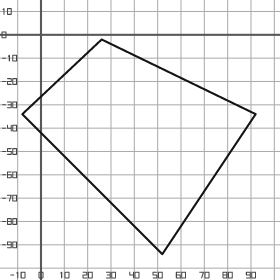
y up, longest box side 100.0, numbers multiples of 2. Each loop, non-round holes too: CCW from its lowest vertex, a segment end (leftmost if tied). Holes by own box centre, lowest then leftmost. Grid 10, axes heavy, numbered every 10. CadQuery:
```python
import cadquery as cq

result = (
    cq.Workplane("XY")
    .moveTo(52.0, -94.0)
    .lineTo(92.0, -34.0)
    .lineTo(26.0, -2.0)
    .lineTo(-8.0, -34.0)
    .close()
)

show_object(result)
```